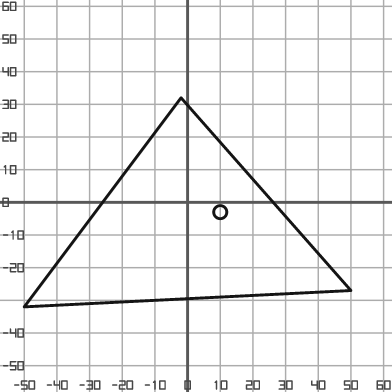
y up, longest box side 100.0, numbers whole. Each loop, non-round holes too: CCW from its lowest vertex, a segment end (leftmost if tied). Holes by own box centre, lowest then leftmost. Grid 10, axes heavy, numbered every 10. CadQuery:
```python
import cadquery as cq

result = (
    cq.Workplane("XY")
    .moveTo(-50.0, -32.0)
    .lineTo(50.0, -27.0)
    .lineTo(-2.0, 32.0)
    .close()
    .moveTo(10.0, -3.0)
    .circle(2.0)
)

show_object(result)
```